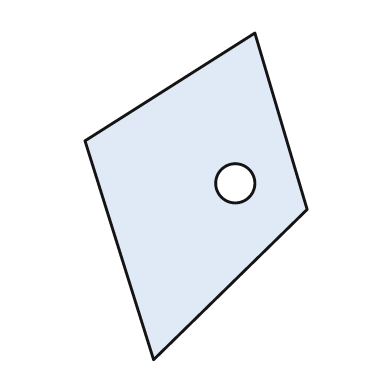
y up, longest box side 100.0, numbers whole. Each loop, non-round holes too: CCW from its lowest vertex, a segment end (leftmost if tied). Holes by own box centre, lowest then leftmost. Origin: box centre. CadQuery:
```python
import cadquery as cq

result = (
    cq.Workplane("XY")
    .moveTo(-13.0, -50.0)
    .lineTo(34.0, -4.0)
    .lineTo(18.0, 50.0)
    .lineTo(-34.0, 17.0)
    .close()
    .moveTo(12.0, 4.0)
    .circle(6.0)
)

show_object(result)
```